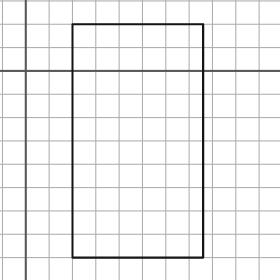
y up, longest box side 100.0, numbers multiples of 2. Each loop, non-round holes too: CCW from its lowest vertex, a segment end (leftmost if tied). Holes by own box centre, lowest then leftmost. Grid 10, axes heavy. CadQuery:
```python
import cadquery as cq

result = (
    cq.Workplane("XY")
    .moveTo(20.0, -80.0)
    .lineTo(76.0, -80.0)
    .lineTo(76.0, 20.0)
    .lineTo(20.0, 20.0)
    .close()
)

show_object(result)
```